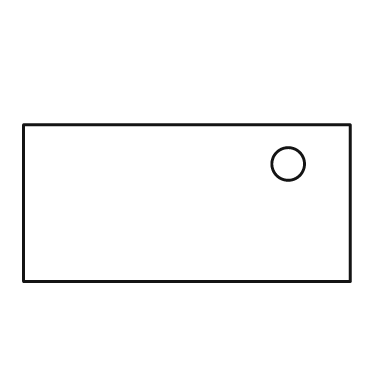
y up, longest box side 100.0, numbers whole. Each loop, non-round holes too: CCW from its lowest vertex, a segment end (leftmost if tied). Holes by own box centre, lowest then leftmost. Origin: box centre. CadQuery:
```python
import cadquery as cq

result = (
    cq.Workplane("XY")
    .moveTo(-50.0, -24.0)
    .lineTo(50.0, -24.0)
    .lineTo(50.0, 24.0)
    .lineTo(-50.0, 24.0)
    .close()
    .moveTo(31.0, 12.0)
    .circle(5.0)
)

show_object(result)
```